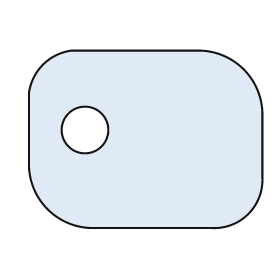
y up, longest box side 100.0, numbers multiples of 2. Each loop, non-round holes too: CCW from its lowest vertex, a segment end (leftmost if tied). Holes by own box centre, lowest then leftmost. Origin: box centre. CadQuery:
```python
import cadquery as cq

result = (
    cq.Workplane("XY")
    .moveTo(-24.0, -38.0)
    .lineTo(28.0, -38.0)
    .threePointArc((44.0, -32.0), (50.0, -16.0))
    .lineTo(50.0, 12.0)
    .threePointArc((42.0, 30.0), (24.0, 38.0))
    .lineTo(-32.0, 38.0)
    .threePointArc((-44.0, 32.0), (-50.0, 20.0))
    .lineTo(-50.0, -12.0)
    .threePointArc((-42.0, -30.0), (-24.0, -38.0))
    .close()
    .moveTo(-26.0, 4.0)
    .circle(10.0)
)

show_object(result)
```